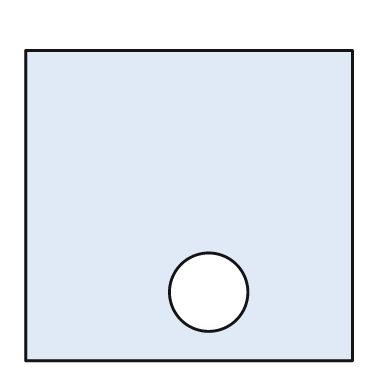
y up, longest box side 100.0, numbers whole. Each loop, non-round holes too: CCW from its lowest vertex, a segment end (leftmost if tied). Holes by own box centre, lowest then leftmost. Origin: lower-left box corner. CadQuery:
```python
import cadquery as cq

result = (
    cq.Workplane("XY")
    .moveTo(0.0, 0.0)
    .lineTo(100.0, 0.0)
    .lineTo(100.0, 95.0)
    .lineTo(0.0, 95.0)
    .close()
    .moveTo(56.0, 21.0)
    .circle(12.0)
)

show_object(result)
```